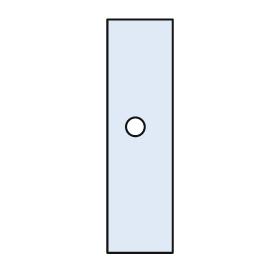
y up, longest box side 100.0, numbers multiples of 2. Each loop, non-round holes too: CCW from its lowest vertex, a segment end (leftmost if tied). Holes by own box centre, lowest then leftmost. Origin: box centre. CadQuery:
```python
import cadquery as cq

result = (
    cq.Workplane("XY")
    .moveTo(-14.0, -50.0)
    .lineTo(14.0, -50.0)
    .lineTo(14.0, 50.0)
    .lineTo(-14.0, 50.0)
    .close()
    .moveTo(-2.0, 4.0)
    .circle(4.0)
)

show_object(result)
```